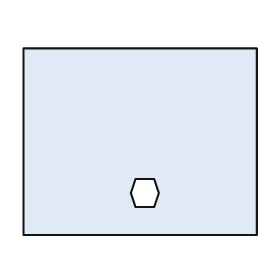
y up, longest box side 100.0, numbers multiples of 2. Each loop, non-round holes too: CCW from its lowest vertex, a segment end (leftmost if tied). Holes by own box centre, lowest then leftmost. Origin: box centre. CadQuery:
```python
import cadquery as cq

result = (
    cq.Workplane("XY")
    .moveTo(-50.0, -40.0)
    .lineTo(50.0, -40.0)
    .lineTo(50.0, 40.0)
    .lineTo(-50.0, 40.0)
    .close()
    .moveTo(-2.0, -28.0)
    .lineTo(6.0, -28.0)
    .lineTo(8.0, -22.0)
    .lineTo(6.0, -16.0)
    .lineTo(-2.0, -16.0)
    .lineTo(-4.0, -22.0)
    .close()
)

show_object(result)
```